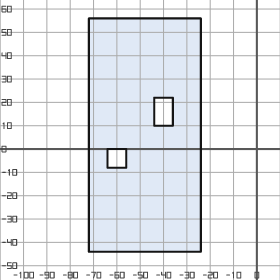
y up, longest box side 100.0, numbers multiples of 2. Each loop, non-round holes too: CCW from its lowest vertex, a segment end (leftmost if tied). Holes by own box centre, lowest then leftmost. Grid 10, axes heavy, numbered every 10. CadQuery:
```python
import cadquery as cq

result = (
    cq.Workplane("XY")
    .moveTo(-72.0, -44.0)
    .lineTo(-24.0, -44.0)
    .lineTo(-24.0, 56.0)
    .lineTo(-72.0, 56.0)
    .close()
    .moveTo(-64.0, -8.0)
    .lineTo(-56.0, -8.0)
    .lineTo(-56.0, 0.0)
    .lineTo(-64.0, 0.0)
    .close()
    .moveTo(-44.0, 10.0)
    .lineTo(-36.0, 10.0)
    .lineTo(-36.0, 22.0)
    .lineTo(-44.0, 22.0)
    .close()
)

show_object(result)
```